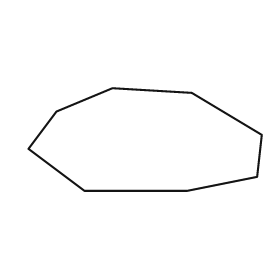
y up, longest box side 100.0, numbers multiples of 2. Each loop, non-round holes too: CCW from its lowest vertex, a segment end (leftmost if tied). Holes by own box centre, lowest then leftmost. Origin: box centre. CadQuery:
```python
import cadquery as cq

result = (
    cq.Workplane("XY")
    .moveTo(-26.0, -22.0)
    .lineTo(18.0, -22.0)
    .lineTo(48.0, -16.0)
    .lineTo(50.0, 2.0)
    .lineTo(20.0, 20.0)
    .lineTo(-14.0, 22.0)
    .lineTo(-38.0, 12.0)
    .lineTo(-50.0, -4.0)
    .close()
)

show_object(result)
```